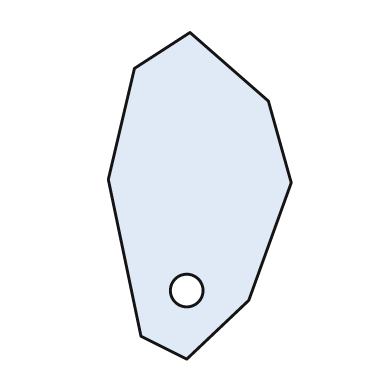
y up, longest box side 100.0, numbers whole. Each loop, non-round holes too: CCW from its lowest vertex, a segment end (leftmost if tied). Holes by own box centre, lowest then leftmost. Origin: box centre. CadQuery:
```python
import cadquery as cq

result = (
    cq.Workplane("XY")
    .moveTo(-4.0, -50.0)
    .lineTo(15.0, -32.0)
    .lineTo(28.0, 4.0)
    .lineTo(21.0, 29.0)
    .lineTo(-3.0, 50.0)
    .lineTo(-20.0, 39.0)
    .lineTo(-28.0, 5.0)
    .lineTo(-18.0, -43.0)
    .close()
    .moveTo(-4.0, -29.0)
    .circle(5.0)
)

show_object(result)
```